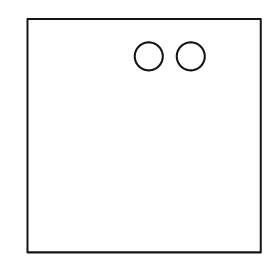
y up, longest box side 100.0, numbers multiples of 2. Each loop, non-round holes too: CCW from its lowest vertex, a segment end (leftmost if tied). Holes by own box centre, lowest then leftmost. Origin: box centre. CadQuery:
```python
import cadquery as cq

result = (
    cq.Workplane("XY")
    .moveTo(-50.0, -50.0)
    .lineTo(50.0, -50.0)
    .lineTo(50.0, 50.0)
    .lineTo(-50.0, 50.0)
    .close()
    .moveTo(2.0, 34.0)
    .circle(6.0)
    .moveTo(20.0, 34.0)
    .circle(6.0)
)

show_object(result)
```